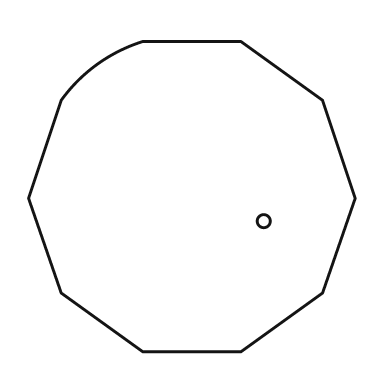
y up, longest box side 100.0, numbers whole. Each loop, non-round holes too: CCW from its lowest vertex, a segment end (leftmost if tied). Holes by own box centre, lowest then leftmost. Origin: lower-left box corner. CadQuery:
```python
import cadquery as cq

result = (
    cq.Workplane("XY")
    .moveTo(35.0, 0.0)
    .lineTo(65.0, 0.0)
    .lineTo(90.0, 18.0)
    .lineTo(100.0, 47.0)
    .lineTo(90.0, 77.0)
    .lineTo(65.0, 95.0)
    .lineTo(35.0, 95.0)
    .threePointArc((21.0, 88.0), (10.0, 77.0))
    .lineTo(0.0, 47.0)
    .lineTo(10.0, 18.0)
    .close()
    .moveTo(72.0, 40.0)
    .circle(2.0)
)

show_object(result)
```